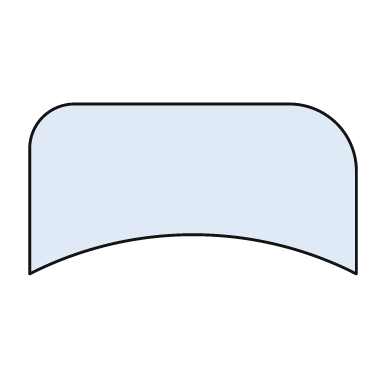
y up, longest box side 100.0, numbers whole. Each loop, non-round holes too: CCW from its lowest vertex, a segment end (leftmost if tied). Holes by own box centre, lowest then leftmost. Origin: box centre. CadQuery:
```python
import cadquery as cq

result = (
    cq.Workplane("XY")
    .moveTo(-50.0, -26.0)
    .threePointArc((0.0, -14.0), (50.0, -26.0))
    .lineTo(50.0, 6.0)
    .threePointArc((44.0, 20.0), (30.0, 26.0))
    .lineTo(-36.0, 26.0)
    .threePointArc((-46.0, 22.0), (-50.0, 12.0))
    .close()
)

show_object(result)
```